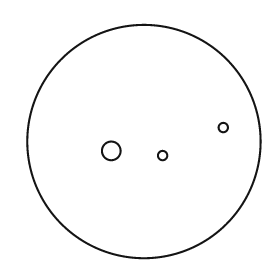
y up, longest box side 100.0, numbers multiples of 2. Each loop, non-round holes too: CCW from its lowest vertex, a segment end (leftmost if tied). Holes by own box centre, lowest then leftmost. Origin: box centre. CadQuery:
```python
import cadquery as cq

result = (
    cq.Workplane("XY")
    .moveTo(0.0, 0.0)
    .circle(50.0)
    .moveTo(8.0, -6.0)
    .circle(2.0)
    .moveTo(-14.0, -4.0)
    .circle(4.0)
    .moveTo(34.0, 6.0)
    .circle(2.0)
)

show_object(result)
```